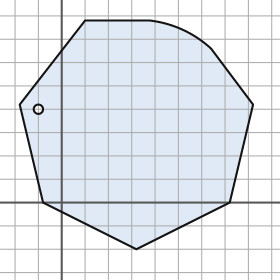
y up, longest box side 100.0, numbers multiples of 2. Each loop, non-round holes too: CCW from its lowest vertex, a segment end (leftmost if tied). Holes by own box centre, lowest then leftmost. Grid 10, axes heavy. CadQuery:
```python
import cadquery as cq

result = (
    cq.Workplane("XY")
    .moveTo(32.0, -20.0)
    .lineTo(72.0, 0.0)
    .lineTo(82.0, 42.0)
    .lineTo(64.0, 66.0)
    .threePointArc((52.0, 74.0), (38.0, 78.0))
    .lineTo(10.0, 78.0)
    .lineTo(-18.0, 42.0)
    .lineTo(-8.0, 0.0)
    .close()
    .moveTo(-10.0, 40.0)
    .circle(2.0)
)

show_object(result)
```